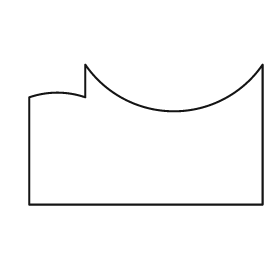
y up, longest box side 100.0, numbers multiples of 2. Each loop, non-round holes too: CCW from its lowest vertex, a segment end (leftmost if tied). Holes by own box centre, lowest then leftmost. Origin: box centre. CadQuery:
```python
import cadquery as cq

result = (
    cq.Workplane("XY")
    .moveTo(-50.0, -30.0)
    .lineTo(50.0, -30.0)
    .lineTo(50.0, 30.0)
    .threePointArc((12.0, 10.0), (-26.0, 30.0))
    .lineTo(-26.0, 16.0)
    .threePointArc((-38.0, 18.0), (-50.0, 16.0))
    .close()
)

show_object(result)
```